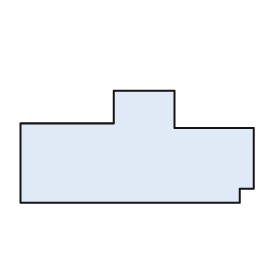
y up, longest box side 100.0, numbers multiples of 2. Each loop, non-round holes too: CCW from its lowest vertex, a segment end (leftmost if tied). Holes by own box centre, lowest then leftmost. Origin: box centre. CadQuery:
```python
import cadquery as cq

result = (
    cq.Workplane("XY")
    .moveTo(-50.0, -24.0)
    .lineTo(44.0, -24.0)
    .lineTo(44.0, -18.0)
    .lineTo(50.0, -18.0)
    .lineTo(50.0, 8.0)
    .lineTo(16.0, 8.0)
    .lineTo(16.0, 24.0)
    .lineTo(-10.0, 24.0)
    .lineTo(-10.0, 10.0)
    .lineTo(-50.0, 10.0)
    .close()
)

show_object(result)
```